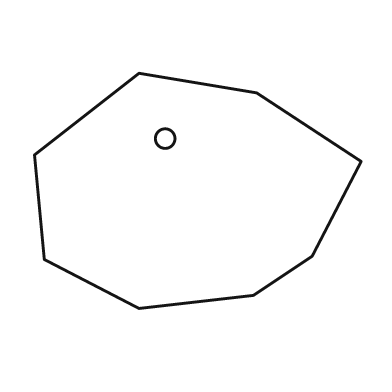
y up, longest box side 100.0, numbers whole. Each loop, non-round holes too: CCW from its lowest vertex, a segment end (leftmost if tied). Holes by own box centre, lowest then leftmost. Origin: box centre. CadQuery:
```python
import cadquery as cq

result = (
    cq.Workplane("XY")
    .moveTo(-18.0, -36.0)
    .lineTo(17.0, -32.0)
    .lineTo(35.0, -20.0)
    .lineTo(50.0, 9.0)
    .lineTo(18.0, 30.0)
    .lineTo(-18.0, 36.0)
    .lineTo(-50.0, 11.0)
    .lineTo(-47.0, -21.0)
    .close()
    .moveTo(-10.0, 16.0)
    .circle(3.0)
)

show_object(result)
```